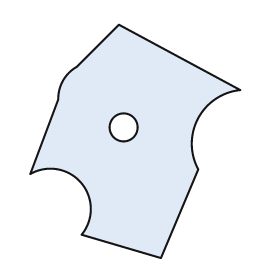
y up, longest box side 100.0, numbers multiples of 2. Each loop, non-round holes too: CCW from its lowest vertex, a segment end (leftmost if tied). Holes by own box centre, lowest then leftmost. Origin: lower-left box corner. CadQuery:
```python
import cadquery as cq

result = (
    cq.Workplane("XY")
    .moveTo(56.0, 0.0)
    .lineTo(72.0, 38.0)
    .threePointArc((72.0, 60.0), (90.0, 72.0))
    .lineTo(38.0, 100.0)
    .lineTo(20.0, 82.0)
    .threePointArc((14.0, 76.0), (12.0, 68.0))
    .lineTo(0.0, 36.0)
    .threePointArc((22.0, 32.0), (22.0, 10.0))
    .close()
    .moveTo(40.0, 56.0)
    .circle(6.0)
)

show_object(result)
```